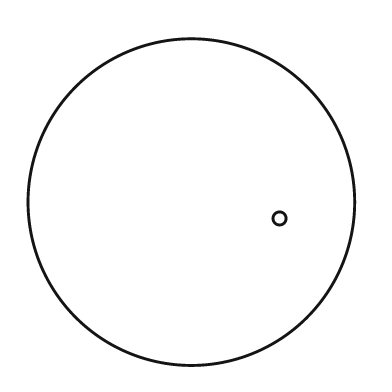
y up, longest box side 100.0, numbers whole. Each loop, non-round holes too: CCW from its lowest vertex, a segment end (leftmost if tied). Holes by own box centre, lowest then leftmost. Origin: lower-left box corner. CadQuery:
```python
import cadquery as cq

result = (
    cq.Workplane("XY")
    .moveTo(50.0, 50.0)
    .circle(50.0)
    .moveTo(77.0, 45.0)
    .circle(2.0)
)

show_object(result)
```